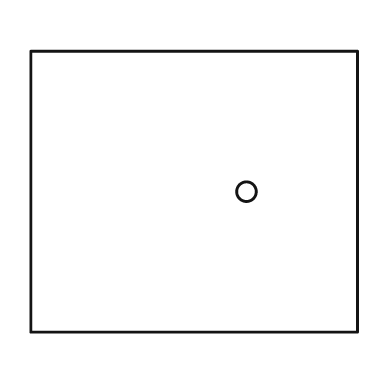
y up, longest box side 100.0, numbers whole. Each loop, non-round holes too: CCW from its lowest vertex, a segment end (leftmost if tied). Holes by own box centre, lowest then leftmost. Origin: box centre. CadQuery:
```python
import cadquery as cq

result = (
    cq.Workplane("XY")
    .moveTo(-50.0, -43.0)
    .lineTo(50.0, -43.0)
    .lineTo(50.0, 43.0)
    .lineTo(-50.0, 43.0)
    .close()
    .moveTo(16.0, 0.0)
    .circle(3.0)
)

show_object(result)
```